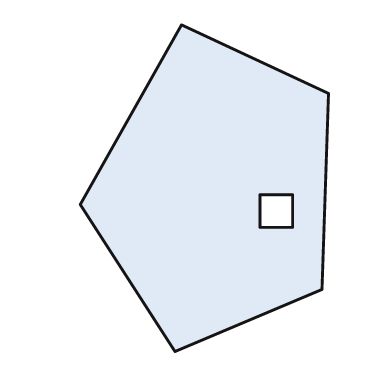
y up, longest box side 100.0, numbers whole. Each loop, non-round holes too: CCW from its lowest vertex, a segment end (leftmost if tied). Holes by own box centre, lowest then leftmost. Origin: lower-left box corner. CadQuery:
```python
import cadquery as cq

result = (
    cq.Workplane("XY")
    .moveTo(29.0, 0.0)
    .lineTo(74.0, 19.0)
    .lineTo(76.0, 79.0)
    .lineTo(31.0, 100.0)
    .lineTo(0.0, 45.0)
    .close()
    .moveTo(55.0, 38.0)
    .lineTo(65.0, 38.0)
    .lineTo(65.0, 48.0)
    .lineTo(55.0, 48.0)
    .close()
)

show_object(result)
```